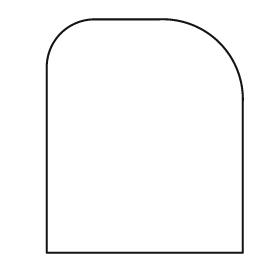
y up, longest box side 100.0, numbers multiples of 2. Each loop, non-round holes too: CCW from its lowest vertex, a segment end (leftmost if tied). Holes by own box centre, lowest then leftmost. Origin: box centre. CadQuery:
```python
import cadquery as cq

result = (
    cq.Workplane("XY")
    .moveTo(-42.0, -50.0)
    .lineTo(42.0, -50.0)
    .lineTo(42.0, 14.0)
    .threePointArc((32.0, 40.0), (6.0, 50.0))
    .lineTo(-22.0, 50.0)
    .threePointArc((-36.0, 44.0), (-42.0, 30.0))
    .close()
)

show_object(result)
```